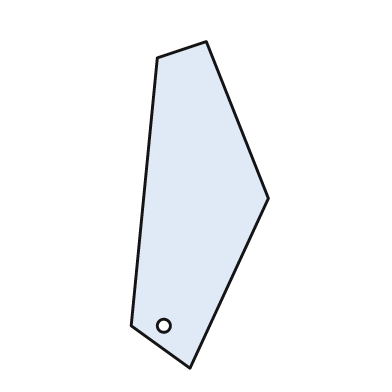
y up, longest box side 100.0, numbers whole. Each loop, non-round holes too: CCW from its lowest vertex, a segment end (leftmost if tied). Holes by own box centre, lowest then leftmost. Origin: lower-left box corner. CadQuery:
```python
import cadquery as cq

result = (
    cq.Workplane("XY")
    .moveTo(18.0, 0.0)
    .lineTo(42.0, 52.0)
    .lineTo(23.0, 100.0)
    .lineTo(8.0, 95.0)
    .lineTo(0.0, 13.0)
    .close()
    .moveTo(10.0, 13.0)
    .circle(2.0)
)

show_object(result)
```